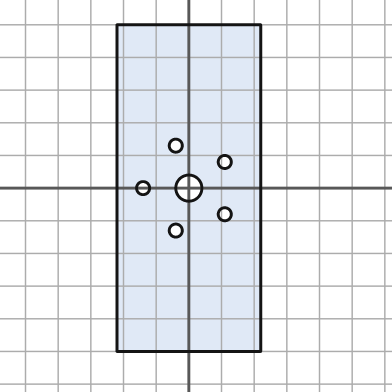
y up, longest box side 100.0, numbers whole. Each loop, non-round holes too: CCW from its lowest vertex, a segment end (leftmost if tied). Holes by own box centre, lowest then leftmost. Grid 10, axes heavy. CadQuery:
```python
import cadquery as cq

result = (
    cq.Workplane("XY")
    .moveTo(-22.0, -50.0)
    .lineTo(22.0, -50.0)
    .lineTo(22.0, 50.0)
    .lineTo(-22.0, 50.0)
    .close()
    .moveTo(-4.0, -13.0)
    .circle(2.0)
    .moveTo(11.0, -8.0)
    .circle(2.0)
    .moveTo(-14.0, 0.0)
    .circle(2.0)
    .moveTo(0.0, 0.0)
    .circle(4.0)
    .moveTo(11.0, 8.0)
    .circle(2.0)
    .moveTo(-4.0, 13.0)
    .circle(2.0)
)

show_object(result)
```